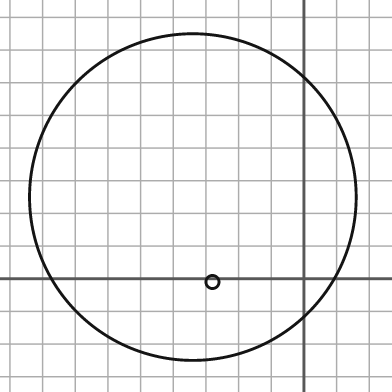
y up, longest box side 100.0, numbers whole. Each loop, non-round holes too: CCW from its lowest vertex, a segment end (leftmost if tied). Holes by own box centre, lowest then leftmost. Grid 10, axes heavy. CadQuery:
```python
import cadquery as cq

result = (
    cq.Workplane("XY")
    .moveTo(-34.0, 25.0)
    .circle(50.0)
    .moveTo(-28.0, -1.0)
    .circle(2.0)
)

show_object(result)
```